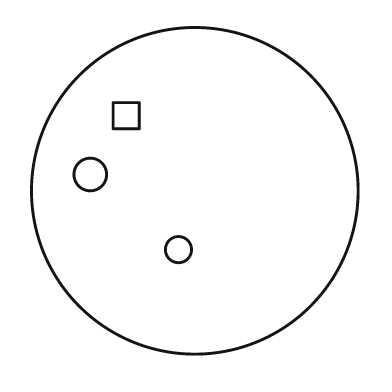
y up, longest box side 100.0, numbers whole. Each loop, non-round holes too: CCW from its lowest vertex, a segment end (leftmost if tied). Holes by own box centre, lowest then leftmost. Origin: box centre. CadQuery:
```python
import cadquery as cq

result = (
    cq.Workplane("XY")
    .moveTo(0.0, 0.0)
    .circle(50.0)
    .moveTo(-5.0, -18.0)
    .circle(4.0)
    .moveTo(-32.0, 5.0)
    .circle(5.0)
    .moveTo(-25.0, 19.0)
    .lineTo(-17.0, 19.0)
    .lineTo(-17.0, 27.0)
    .lineTo(-25.0, 27.0)
    .close()
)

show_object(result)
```